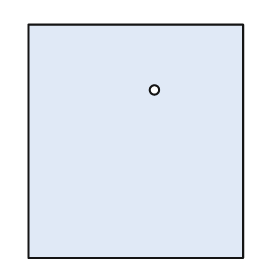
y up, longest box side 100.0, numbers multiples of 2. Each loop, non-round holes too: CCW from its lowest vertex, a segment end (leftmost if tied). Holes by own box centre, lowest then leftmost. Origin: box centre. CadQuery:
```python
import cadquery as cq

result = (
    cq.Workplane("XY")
    .moveTo(-46.0, -50.0)
    .lineTo(46.0, -50.0)
    .lineTo(46.0, 50.0)
    .lineTo(-46.0, 50.0)
    .close()
    .moveTo(8.0, 22.0)
    .circle(2.0)
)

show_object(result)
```